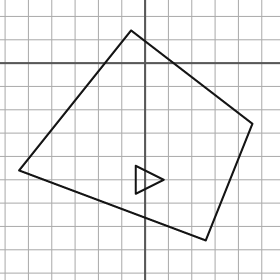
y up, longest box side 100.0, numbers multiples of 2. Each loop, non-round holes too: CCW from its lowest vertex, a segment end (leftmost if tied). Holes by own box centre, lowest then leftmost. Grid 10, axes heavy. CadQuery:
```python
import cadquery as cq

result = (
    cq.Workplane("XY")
    .moveTo(26.0, -76.0)
    .lineTo(46.0, -26.0)
    .lineTo(-6.0, 14.0)
    .lineTo(-54.0, -46.0)
    .close()
    .moveTo(-4.0, -56.0)
    .lineTo(8.0, -50.0)
    .lineTo(-4.0, -44.0)
    .close()
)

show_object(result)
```